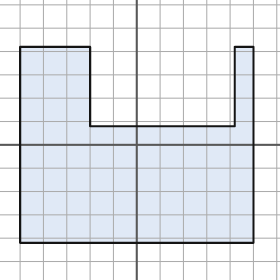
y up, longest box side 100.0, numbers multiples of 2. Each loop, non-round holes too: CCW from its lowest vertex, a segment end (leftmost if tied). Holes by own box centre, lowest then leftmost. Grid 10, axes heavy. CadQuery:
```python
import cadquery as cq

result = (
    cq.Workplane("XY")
    .moveTo(-50.0, -42.0)
    .lineTo(50.0, -42.0)
    .lineTo(50.0, 42.0)
    .lineTo(42.0, 42.0)
    .lineTo(42.0, 8.0)
    .lineTo(-20.0, 8.0)
    .lineTo(-20.0, 42.0)
    .lineTo(-50.0, 42.0)
    .close()
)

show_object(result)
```